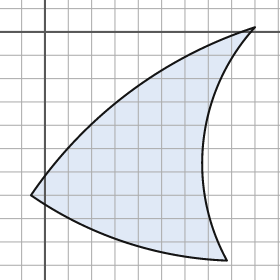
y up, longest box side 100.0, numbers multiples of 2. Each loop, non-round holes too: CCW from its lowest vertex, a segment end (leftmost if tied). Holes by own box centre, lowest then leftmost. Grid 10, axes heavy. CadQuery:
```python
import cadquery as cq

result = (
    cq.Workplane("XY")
    .moveTo(78.0, -98.0)
    .threePointArc((68.0, -46.0), (90.0, 2.0))
    .threePointArc((36.0, -26.0), (-6.0, -70.0))
    .threePointArc((34.0, -90.0), (78.0, -98.0))
    .close()
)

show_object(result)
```